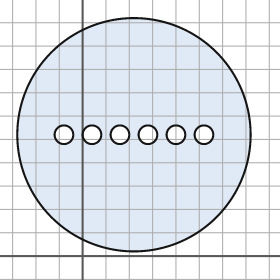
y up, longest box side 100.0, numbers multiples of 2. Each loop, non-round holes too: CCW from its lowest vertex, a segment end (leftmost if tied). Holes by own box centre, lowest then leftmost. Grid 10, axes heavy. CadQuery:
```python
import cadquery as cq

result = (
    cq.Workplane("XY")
    .moveTo(22.0, 52.0)
    .circle(50.0)
    .moveTo(-8.0, 52.0)
    .circle(4.0)
    .moveTo(4.0, 52.0)
    .circle(4.0)
    .moveTo(16.0, 52.0)
    .circle(4.0)
    .moveTo(28.0, 52.0)
    .circle(4.0)
    .moveTo(40.0, 52.0)
    .circle(4.0)
    .moveTo(52.0, 52.0)
    .circle(4.0)
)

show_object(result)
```